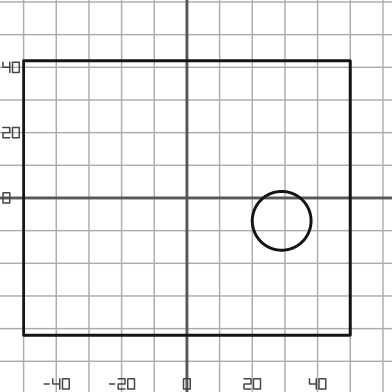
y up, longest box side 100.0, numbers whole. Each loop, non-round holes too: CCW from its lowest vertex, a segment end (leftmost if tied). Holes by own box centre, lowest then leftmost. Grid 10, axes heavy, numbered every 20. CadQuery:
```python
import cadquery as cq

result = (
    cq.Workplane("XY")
    .moveTo(-50.0, -42.0)
    .lineTo(50.0, -42.0)
    .lineTo(50.0, 42.0)
    .lineTo(-50.0, 42.0)
    .close()
    .moveTo(29.0, -7.0)
    .circle(9.0)
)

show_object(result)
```